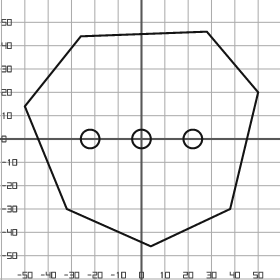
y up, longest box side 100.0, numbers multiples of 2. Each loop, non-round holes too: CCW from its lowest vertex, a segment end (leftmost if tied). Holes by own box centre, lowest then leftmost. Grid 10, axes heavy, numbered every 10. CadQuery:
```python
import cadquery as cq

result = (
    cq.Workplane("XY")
    .moveTo(4.0, -46.0)
    .lineTo(38.0, -30.0)
    .lineTo(50.0, 20.0)
    .lineTo(28.0, 46.0)
    .lineTo(-26.0, 44.0)
    .lineTo(-50.0, 14.0)
    .lineTo(-32.0, -30.0)
    .close()
    .moveTo(-22.0, 0.0)
    .circle(4.0)
    .moveTo(0.0, 0.0)
    .circle(4.0)
    .moveTo(22.0, 0.0)
    .circle(4.0)
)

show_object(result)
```